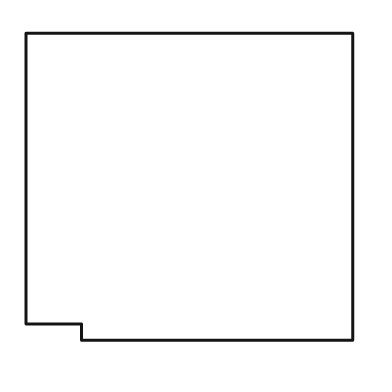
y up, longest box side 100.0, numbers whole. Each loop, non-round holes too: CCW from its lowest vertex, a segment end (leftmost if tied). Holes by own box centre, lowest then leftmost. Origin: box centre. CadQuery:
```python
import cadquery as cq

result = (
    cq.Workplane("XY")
    .moveTo(-33.0, -47.0)
    .lineTo(50.0, -47.0)
    .lineTo(50.0, 47.0)
    .lineTo(-50.0, 47.0)
    .lineTo(-50.0, -42.0)
    .lineTo(-33.0, -42.0)
    .close()
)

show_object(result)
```